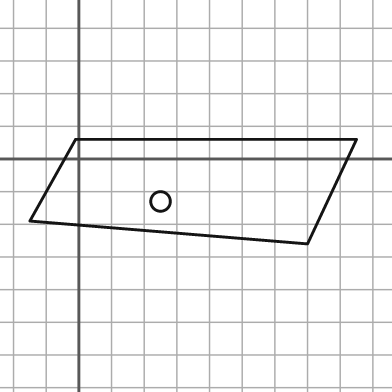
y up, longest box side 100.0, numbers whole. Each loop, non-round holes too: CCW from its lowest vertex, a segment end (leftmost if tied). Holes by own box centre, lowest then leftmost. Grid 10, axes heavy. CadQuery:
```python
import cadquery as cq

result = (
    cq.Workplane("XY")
    .moveTo(70.0, -26.0)
    .lineTo(85.0, 6.0)
    .lineTo(-1.0, 6.0)
    .lineTo(-15.0, -19.0)
    .close()
    .moveTo(25.0, -13.0)
    .circle(3.0)
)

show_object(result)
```